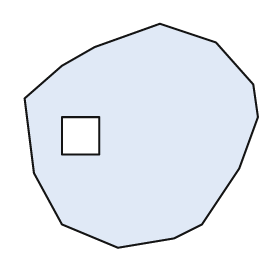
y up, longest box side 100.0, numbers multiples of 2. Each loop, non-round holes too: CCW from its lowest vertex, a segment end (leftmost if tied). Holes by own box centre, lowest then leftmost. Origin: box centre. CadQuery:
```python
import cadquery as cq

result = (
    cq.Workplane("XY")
    .moveTo(-10.0, -48.0)
    .lineTo(14.0, -44.0)
    .lineTo(26.0, -38.0)
    .lineTo(42.0, -14.0)
    .lineTo(50.0, 8.0)
    .lineTo(48.0, 22.0)
    .lineTo(32.0, 40.0)
    .lineTo(8.0, 48.0)
    .lineTo(-20.0, 38.0)
    .lineTo(-34.0, 30.0)
    .lineTo(-50.0, 16.0)
    .lineTo(-46.0, -16.0)
    .lineTo(-34.0, -38.0)
    .close()
    .moveTo(-34.0, -8.0)
    .lineTo(-18.0, -8.0)
    .lineTo(-18.0, 8.0)
    .lineTo(-34.0, 8.0)
    .close()
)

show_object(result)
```